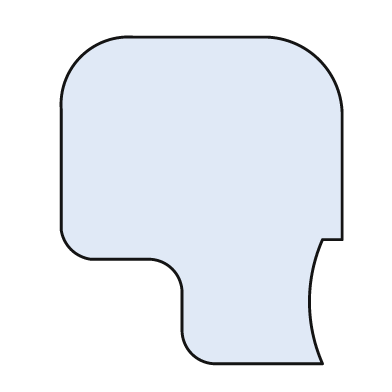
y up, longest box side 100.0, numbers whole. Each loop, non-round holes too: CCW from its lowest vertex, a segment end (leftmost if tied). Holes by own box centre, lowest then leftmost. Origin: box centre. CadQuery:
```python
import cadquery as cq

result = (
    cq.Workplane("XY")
    .moveTo(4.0, -50.0)
    .lineTo(37.0, -50.0)
    .threePointArc((33.0, -31.0), (37.0, -12.0))
    .lineTo(43.0, -12.0)
    .lineTo(43.0, 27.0)
    .threePointArc((36.0, 43.0), (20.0, 50.0))
    .lineTo(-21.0, 50.0)
    .threePointArc((-37.0, 44.0), (-43.0, 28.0))
    .lineTo(-43.0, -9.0)
    .threePointArc((-40.0, -15.0), (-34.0, -18.0))
    .lineTo(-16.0, -18.0)
    .threePointArc((-9.0, -21.0), (-6.0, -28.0))
    .lineTo(-6.0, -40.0)
    .threePointArc((-3.0, -47.0), (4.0, -50.0))
    .close()
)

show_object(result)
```